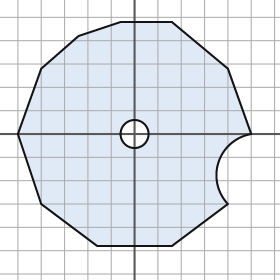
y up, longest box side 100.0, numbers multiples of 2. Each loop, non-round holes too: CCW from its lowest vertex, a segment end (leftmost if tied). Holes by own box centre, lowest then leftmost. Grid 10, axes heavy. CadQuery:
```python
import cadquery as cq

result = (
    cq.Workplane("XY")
    .moveTo(-16.0, -48.0)
    .lineTo(16.0, -48.0)
    .lineTo(40.0, -30.0)
    .threePointArc((36.0, -12.0), (50.0, 0.0))
    .lineTo(40.0, 28.0)
    .lineTo(16.0, 48.0)
    .lineTo(-6.0, 48.0)
    .lineTo(-24.0, 42.0)
    .lineTo(-40.0, 28.0)
    .lineTo(-50.0, 0.0)
    .lineTo(-40.0, -30.0)
    .close()
    .moveTo(0.0, 0.0)
    .circle(6.0)
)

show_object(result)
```